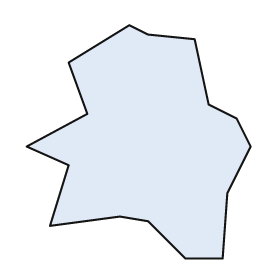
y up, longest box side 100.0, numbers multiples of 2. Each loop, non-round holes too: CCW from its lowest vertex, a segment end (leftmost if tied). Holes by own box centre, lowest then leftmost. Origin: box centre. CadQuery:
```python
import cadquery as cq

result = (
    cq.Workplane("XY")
    .moveTo(20.0, -50.0)
    .lineTo(36.0, -50.0)
    .lineTo(38.0, -22.0)
    .lineTo(48.0, -2.0)
    .lineTo(42.0, 10.0)
    .lineTo(30.0, 16.0)
    .lineTo(24.0, 44.0)
    .lineTo(4.0, 46.0)
    .lineTo(-4.0, 50.0)
    .lineTo(-30.0, 34.0)
    .lineTo(-22.0, 12.0)
    .lineTo(-48.0, -2.0)
    .lineTo(-30.0, -10.0)
    .lineTo(-38.0, -36.0)
    .lineTo(-8.0, -32.0)
    .lineTo(4.0, -34.0)
    .close()
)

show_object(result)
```